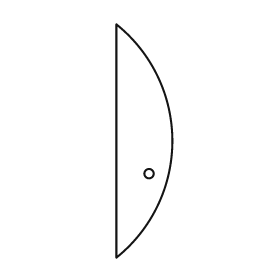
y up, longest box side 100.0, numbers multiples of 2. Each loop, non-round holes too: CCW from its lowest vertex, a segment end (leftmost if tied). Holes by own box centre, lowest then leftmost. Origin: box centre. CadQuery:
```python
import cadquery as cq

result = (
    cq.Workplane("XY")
    .moveTo(-12.0, -50.0)
    .threePointArc((12.0, 0.0), (-12.0, 50.0))
    .close()
    .moveTo(2.0, -14.0)
    .circle(2.0)
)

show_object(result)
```